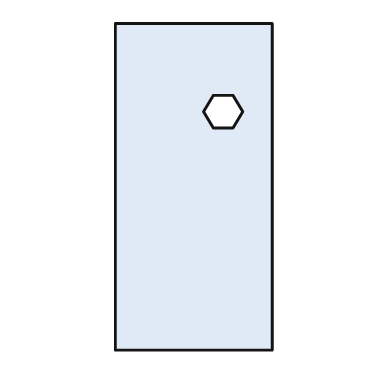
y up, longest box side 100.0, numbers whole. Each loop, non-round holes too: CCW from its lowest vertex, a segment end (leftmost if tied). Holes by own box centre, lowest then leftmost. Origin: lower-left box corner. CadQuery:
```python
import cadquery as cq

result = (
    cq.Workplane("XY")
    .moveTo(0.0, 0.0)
    .lineTo(48.0, 0.0)
    .lineTo(48.0, 100.0)
    .lineTo(0.0, 100.0)
    .close()
    .moveTo(30.0, 68.0)
    .lineTo(36.0, 68.0)
    .lineTo(39.0, 73.0)
    .lineTo(36.0, 78.0)
    .lineTo(30.0, 78.0)
    .lineTo(27.0, 73.0)
    .close()
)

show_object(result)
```